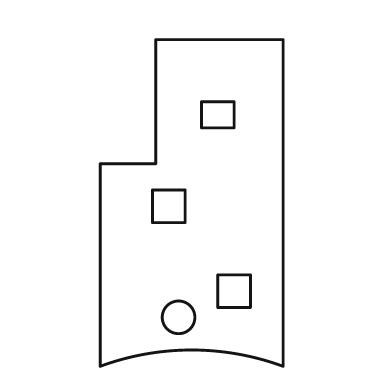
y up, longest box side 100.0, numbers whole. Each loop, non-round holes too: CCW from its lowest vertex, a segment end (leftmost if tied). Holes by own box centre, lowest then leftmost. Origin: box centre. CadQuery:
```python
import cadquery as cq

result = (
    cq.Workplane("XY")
    .moveTo(-28.0, -50.0)
    .threePointArc((0.0, -45.0), (28.0, -50.0))
    .lineTo(28.0, 50.0)
    .lineTo(-11.0, 50.0)
    .lineTo(-11.0, 12.0)
    .lineTo(-28.0, 12.0)
    .close()
    .moveTo(-4.0, -35.0)
    .circle(5.0)
    .moveTo(8.0, -32.0)
    .lineTo(18.0, -32.0)
    .lineTo(18.0, -22.0)
    .lineTo(8.0, -22.0)
    .close()
    .moveTo(-12.0, -6.0)
    .lineTo(-2.0, -6.0)
    .lineTo(-2.0, 4.0)
    .lineTo(-12.0, 4.0)
    .close()
    .moveTo(3.0, 23.0)
    .lineTo(13.0, 23.0)
    .lineTo(13.0, 31.0)
    .lineTo(3.0, 31.0)
    .close()
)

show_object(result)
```